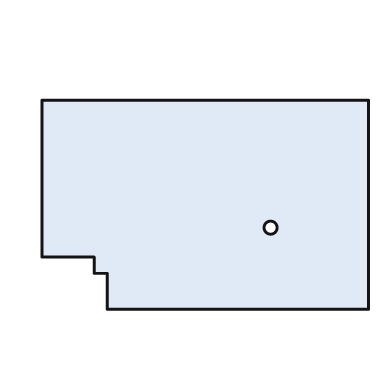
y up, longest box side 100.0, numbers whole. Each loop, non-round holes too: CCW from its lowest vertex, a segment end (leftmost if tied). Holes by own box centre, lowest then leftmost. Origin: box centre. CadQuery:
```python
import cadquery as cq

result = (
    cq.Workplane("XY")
    .moveTo(-30.0, -32.0)
    .lineTo(50.0, -32.0)
    .lineTo(50.0, 32.0)
    .lineTo(-50.0, 32.0)
    .lineTo(-50.0, -16.0)
    .lineTo(-34.0, -16.0)
    .lineTo(-34.0, -21.0)
    .lineTo(-30.0, -21.0)
    .close()
    .moveTo(20.0, -7.0)
    .circle(2.0)
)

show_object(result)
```